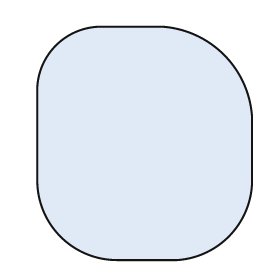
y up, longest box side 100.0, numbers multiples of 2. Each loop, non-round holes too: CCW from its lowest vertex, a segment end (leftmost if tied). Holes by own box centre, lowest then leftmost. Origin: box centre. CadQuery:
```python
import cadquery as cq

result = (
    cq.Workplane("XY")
    .moveTo(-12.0, -50.0)
    .lineTo(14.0, -50.0)
    .threePointArc((36.0, -40.0), (46.0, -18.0))
    .lineTo(46.0, 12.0)
    .threePointArc((34.0, 38.0), (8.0, 50.0))
    .lineTo(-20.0, 50.0)
    .threePointArc((-38.0, 42.0), (-46.0, 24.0))
    .lineTo(-46.0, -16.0)
    .threePointArc((-36.0, -40.0), (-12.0, -50.0))
    .close()
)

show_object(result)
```